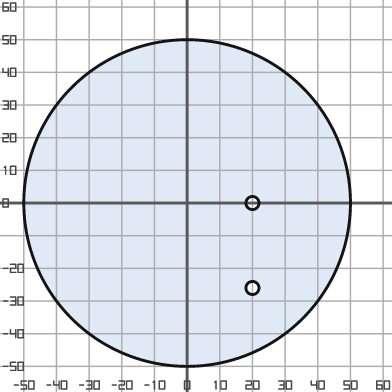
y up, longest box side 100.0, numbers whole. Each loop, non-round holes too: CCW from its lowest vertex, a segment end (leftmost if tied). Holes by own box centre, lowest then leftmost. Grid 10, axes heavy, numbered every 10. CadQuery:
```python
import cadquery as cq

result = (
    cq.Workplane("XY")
    .moveTo(0.0, 0.0)
    .circle(50.0)
    .moveTo(20.0, -26.0)
    .circle(2.0)
    .moveTo(20.0, 0.0)
    .circle(2.0)
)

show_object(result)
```